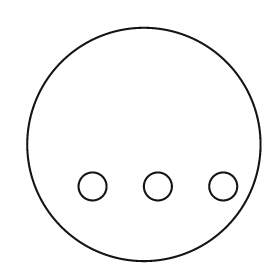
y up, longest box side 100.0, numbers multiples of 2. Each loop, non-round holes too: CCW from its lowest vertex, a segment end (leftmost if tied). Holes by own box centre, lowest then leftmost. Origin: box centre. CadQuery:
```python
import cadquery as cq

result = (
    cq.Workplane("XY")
    .moveTo(0.0, 0.0)
    .circle(50.0)
    .moveTo(-22.0, -18.0)
    .circle(6.0)
    .moveTo(6.0, -18.0)
    .circle(6.0)
    .moveTo(34.0, -18.0)
    .circle(6.0)
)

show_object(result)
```